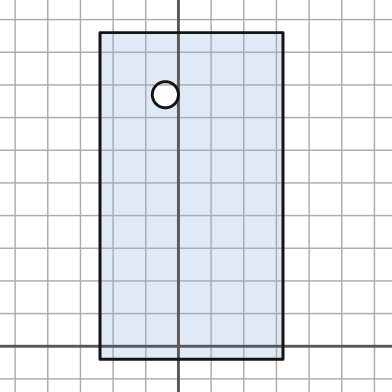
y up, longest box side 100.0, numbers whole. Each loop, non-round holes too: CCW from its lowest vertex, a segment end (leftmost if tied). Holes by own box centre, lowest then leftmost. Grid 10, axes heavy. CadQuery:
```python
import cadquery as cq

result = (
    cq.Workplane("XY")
    .moveTo(-24.0, -4.0)
    .lineTo(32.0, -4.0)
    .lineTo(32.0, 96.0)
    .lineTo(-24.0, 96.0)
    .close()
    .moveTo(-4.0, 77.0)
    .circle(4.0)
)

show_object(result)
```